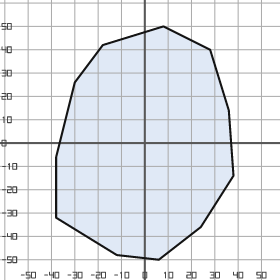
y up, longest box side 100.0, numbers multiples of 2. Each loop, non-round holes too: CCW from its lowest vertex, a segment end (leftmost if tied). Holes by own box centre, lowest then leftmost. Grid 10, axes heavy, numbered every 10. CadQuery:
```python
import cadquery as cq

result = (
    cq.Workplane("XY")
    .moveTo(6.0, -50.0)
    .lineTo(24.0, -36.0)
    .lineTo(38.0, -14.0)
    .lineTo(36.0, 14.0)
    .lineTo(28.0, 40.0)
    .lineTo(8.0, 50.0)
    .lineTo(-18.0, 42.0)
    .lineTo(-30.0, 26.0)
    .lineTo(-38.0, -6.0)
    .lineTo(-38.0, -32.0)
    .lineTo(-12.0, -48.0)
    .close()
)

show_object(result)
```